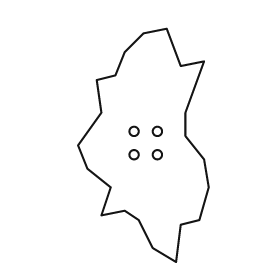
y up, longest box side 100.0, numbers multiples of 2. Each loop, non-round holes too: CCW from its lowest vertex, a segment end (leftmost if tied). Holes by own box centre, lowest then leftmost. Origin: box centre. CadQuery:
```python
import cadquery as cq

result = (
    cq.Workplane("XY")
    .moveTo(14.0, -50.0)
    .lineTo(16.0, -34.0)
    .lineTo(24.0, -32.0)
    .lineTo(28.0, -18.0)
    .lineTo(26.0, -6.0)
    .lineTo(18.0, 4.0)
    .lineTo(18.0, 14.0)
    .lineTo(26.0, 36.0)
    .lineTo(16.0, 34.0)
    .lineTo(10.0, 50.0)
    .lineTo(0.0, 48.0)
    .lineTo(-8.0, 40.0)
    .lineTo(-12.0, 30.0)
    .lineTo(-20.0, 28.0)
    .lineTo(-18.0, 14.0)
    .lineTo(-28.0, 0.0)
    .lineTo(-24.0, -10.0)
    .lineTo(-14.0, -18.0)
    .lineTo(-18.0, -30.0)
    .lineTo(-8.0, -28.0)
    .lineTo(-2.0, -32.0)
    .lineTo(4.0, -44.0)
    .close()
    .moveTo(-4.0, -4.0)
    .circle(2.0)
    .moveTo(6.0, -4.0)
    .circle(2.0)
    .moveTo(-4.0, 6.0)
    .circle(2.0)
    .moveTo(6.0, 6.0)
    .circle(2.0)
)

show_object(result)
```